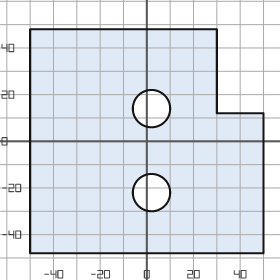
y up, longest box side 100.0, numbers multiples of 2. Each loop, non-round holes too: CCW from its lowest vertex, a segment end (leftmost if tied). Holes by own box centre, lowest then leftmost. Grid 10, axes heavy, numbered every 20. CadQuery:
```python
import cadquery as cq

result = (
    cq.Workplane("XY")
    .moveTo(-50.0, -48.0)
    .lineTo(50.0, -48.0)
    .lineTo(50.0, 12.0)
    .lineTo(30.0, 12.0)
    .lineTo(30.0, 48.0)
    .lineTo(-50.0, 48.0)
    .close()
    .moveTo(2.0, -22.0)
    .circle(8.0)
    .moveTo(2.0, 14.0)
    .circle(8.0)
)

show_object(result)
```